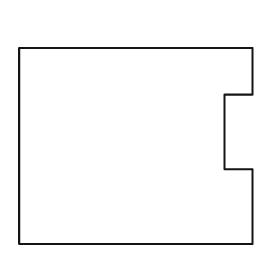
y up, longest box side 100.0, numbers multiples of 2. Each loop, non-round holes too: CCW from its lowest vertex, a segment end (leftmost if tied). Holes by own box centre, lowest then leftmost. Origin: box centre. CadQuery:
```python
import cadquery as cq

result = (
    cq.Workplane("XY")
    .moveTo(-50.0, -42.0)
    .lineTo(50.0, -42.0)
    .lineTo(50.0, -10.0)
    .lineTo(38.0, -10.0)
    .lineTo(38.0, 22.0)
    .lineTo(50.0, 22.0)
    .lineTo(50.0, 42.0)
    .lineTo(-50.0, 42.0)
    .close()
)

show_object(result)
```